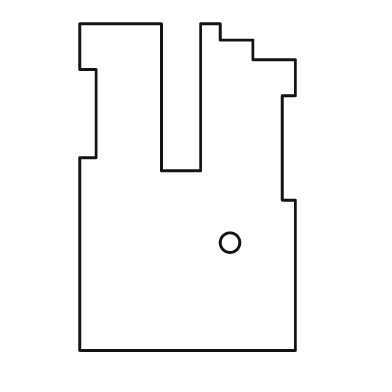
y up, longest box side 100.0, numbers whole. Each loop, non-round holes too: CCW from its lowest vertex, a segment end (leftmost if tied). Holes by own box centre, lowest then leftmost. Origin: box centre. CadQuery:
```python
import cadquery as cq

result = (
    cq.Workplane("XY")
    .moveTo(-33.0, -50.0)
    .lineTo(33.0, -50.0)
    .lineTo(33.0, -4.0)
    .lineTo(29.0, -4.0)
    .lineTo(29.0, 28.0)
    .lineTo(33.0, 28.0)
    .lineTo(33.0, 39.0)
    .lineTo(20.0, 39.0)
    .lineTo(20.0, 45.0)
    .lineTo(10.0, 45.0)
    .lineTo(10.0, 50.0)
    .lineTo(4.0, 50.0)
    .lineTo(4.0, 5.0)
    .lineTo(-8.0, 5.0)
    .lineTo(-8.0, 50.0)
    .lineTo(-33.0, 50.0)
    .lineTo(-33.0, 36.0)
    .lineTo(-28.0, 36.0)
    .lineTo(-28.0, 9.0)
    .lineTo(-33.0, 9.0)
    .close()
    .moveTo(13.0, -17.0)
    .circle(3.0)
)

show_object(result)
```